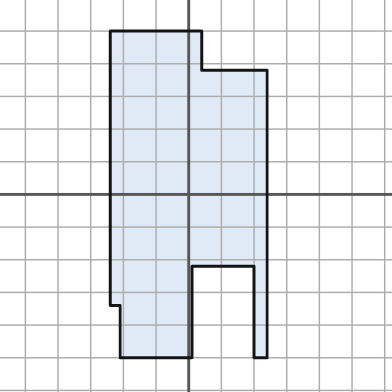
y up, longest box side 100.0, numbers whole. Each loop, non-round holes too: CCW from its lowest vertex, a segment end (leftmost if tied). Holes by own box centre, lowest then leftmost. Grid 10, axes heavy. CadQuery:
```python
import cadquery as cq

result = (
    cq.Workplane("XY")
    .moveTo(-21.0, -50.0)
    .lineTo(1.0, -50.0)
    .lineTo(1.0, -22.0)
    .lineTo(20.0, -22.0)
    .lineTo(20.0, -50.0)
    .lineTo(24.0, -50.0)
    .lineTo(24.0, 38.0)
    .lineTo(4.0, 38.0)
    .lineTo(4.0, 50.0)
    .lineTo(-24.0, 50.0)
    .lineTo(-24.0, -34.0)
    .lineTo(-21.0, -34.0)
    .close()
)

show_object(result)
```